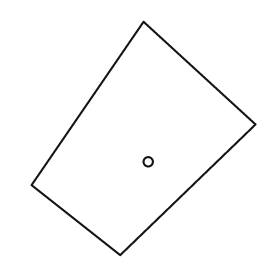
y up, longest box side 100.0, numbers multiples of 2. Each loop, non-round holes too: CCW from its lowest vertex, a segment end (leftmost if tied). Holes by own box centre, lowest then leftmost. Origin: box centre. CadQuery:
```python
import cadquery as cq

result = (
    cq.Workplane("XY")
    .moveTo(-10.0, -50.0)
    .lineTo(48.0, 6.0)
    .lineTo(0.0, 50.0)
    .lineTo(-48.0, -20.0)
    .close()
    .moveTo(2.0, -10.0)
    .circle(2.0)
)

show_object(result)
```